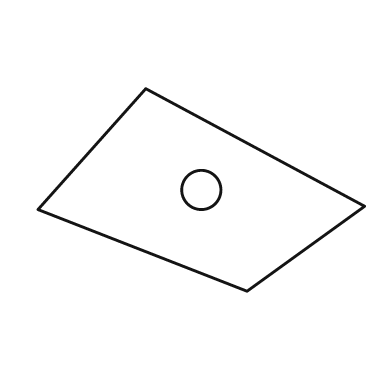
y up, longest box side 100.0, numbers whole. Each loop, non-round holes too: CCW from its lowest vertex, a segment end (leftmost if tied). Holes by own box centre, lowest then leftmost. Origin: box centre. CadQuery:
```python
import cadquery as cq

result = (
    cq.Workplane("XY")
    .moveTo(14.0, -31.0)
    .lineTo(50.0, -5.0)
    .lineTo(-17.0, 31.0)
    .lineTo(-50.0, -6.0)
    .close()
    .moveTo(0.0, 0.0)
    .circle(6.0)
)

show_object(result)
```